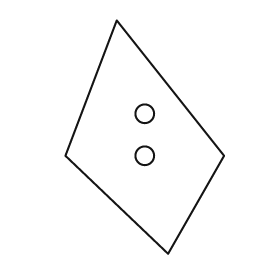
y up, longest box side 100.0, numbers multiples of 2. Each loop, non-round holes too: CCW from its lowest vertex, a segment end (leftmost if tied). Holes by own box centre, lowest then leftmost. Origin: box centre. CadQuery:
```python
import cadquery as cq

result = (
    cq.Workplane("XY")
    .moveTo(10.0, -50.0)
    .lineTo(34.0, -8.0)
    .lineTo(-12.0, 50.0)
    .lineTo(-34.0, -8.0)
    .close()
    .moveTo(0.0, -8.0)
    .circle(4.0)
    .moveTo(0.0, 10.0)
    .circle(4.0)
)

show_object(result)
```